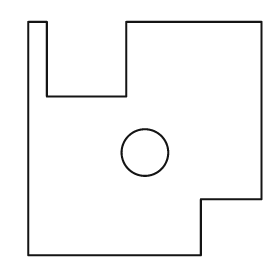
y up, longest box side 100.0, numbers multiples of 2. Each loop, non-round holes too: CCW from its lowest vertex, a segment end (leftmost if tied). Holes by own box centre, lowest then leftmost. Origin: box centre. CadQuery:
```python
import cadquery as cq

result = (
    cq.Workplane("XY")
    .moveTo(-50.0, -50.0)
    .lineTo(24.0, -50.0)
    .lineTo(24.0, -26.0)
    .lineTo(50.0, -26.0)
    .lineTo(50.0, 50.0)
    .lineTo(-8.0, 50.0)
    .lineTo(-8.0, 18.0)
    .lineTo(-42.0, 18.0)
    .lineTo(-42.0, 50.0)
    .lineTo(-50.0, 50.0)
    .close()
    .moveTo(0.0, -6.0)
    .circle(10.0)
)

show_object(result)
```